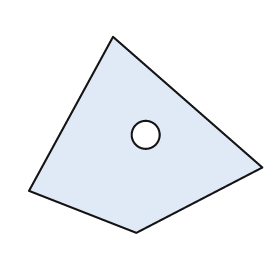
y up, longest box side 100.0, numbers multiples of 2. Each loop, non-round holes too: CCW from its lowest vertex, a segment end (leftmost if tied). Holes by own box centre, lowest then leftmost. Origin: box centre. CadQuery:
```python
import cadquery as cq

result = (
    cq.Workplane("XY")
    .moveTo(-4.0, -42.0)
    .lineTo(50.0, -14.0)
    .lineTo(-14.0, 42.0)
    .lineTo(-50.0, -24.0)
    .close()
    .moveTo(0.0, 0.0)
    .circle(6.0)
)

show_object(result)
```